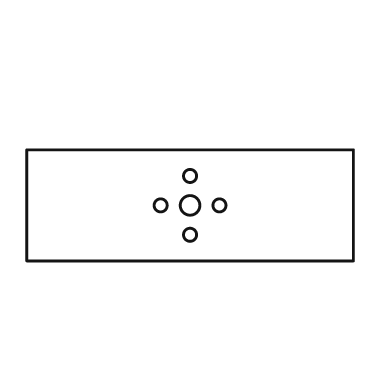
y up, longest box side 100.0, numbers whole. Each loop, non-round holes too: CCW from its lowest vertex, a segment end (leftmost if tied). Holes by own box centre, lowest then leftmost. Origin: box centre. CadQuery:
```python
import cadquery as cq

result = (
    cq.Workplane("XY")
    .moveTo(-50.0, -17.0)
    .lineTo(50.0, -17.0)
    .lineTo(50.0, 17.0)
    .lineTo(-50.0, 17.0)
    .close()
    .moveTo(0.0, -9.0)
    .circle(2.0)
    .moveTo(-9.0, 0.0)
    .circle(2.0)
    .moveTo(0.0, 0.0)
    .circle(3.0)
    .moveTo(9.0, 0.0)
    .circle(2.0)
    .moveTo(0.0, 9.0)
    .circle(2.0)
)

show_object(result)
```